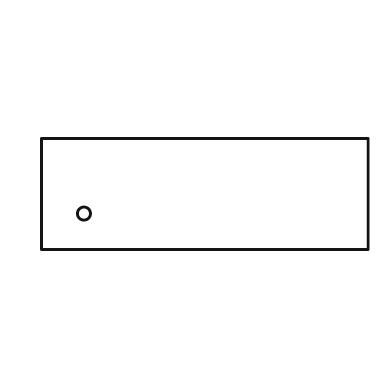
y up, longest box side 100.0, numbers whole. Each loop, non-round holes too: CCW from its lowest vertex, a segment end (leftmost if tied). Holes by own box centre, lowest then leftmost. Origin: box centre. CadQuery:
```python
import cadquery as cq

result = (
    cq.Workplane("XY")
    .moveTo(-50.0, -17.0)
    .lineTo(50.0, -17.0)
    .lineTo(50.0, 17.0)
    .lineTo(-50.0, 17.0)
    .close()
    .moveTo(-37.0, -6.0)
    .circle(2.0)
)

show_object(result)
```